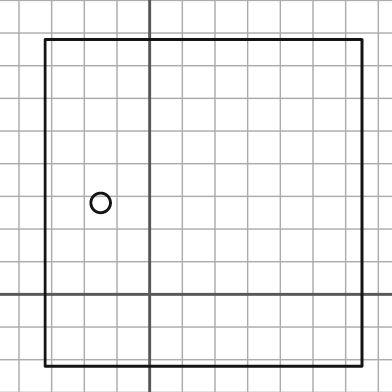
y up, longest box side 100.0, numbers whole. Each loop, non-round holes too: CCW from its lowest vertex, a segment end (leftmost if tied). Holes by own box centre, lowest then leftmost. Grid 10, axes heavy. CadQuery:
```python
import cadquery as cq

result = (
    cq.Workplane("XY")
    .moveTo(-32.0, -22.0)
    .lineTo(65.0, -22.0)
    .lineTo(65.0, 78.0)
    .lineTo(-32.0, 78.0)
    .close()
    .moveTo(-15.0, 28.0)
    .circle(3.0)
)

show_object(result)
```